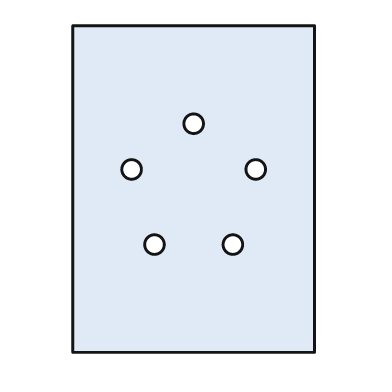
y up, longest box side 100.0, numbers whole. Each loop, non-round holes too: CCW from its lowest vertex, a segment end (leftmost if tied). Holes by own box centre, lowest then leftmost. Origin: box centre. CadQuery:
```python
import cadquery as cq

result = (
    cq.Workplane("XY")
    .moveTo(-37.0, -50.0)
    .lineTo(37.0, -50.0)
    .lineTo(37.0, 50.0)
    .lineTo(-37.0, 50.0)
    .close()
    .moveTo(-12.0, -17.0)
    .circle(3.0)
    .moveTo(12.0, -17.0)
    .circle(3.0)
    .moveTo(-19.0, 6.0)
    .circle(3.0)
    .moveTo(19.0, 6.0)
    .circle(3.0)
    .moveTo(0.0, 20.0)
    .circle(3.0)
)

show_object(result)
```